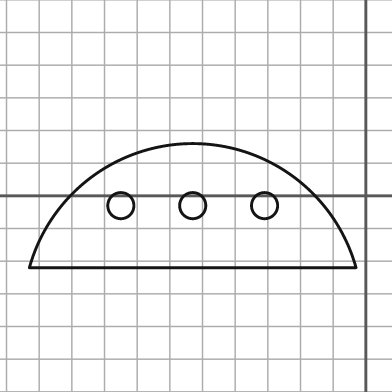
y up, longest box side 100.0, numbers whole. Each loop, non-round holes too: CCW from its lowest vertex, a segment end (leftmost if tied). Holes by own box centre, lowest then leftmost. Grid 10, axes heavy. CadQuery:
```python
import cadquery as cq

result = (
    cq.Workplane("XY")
    .moveTo(-103.0, -22.0)
    .lineTo(-3.0, -22.0)
    .threePointArc((-53.0, 16.0), (-103.0, -22.0))
    .close()
    .moveTo(-75.0, -3.0)
    .circle(4.0)
    .moveTo(-53.0, -3.0)
    .circle(4.0)
    .moveTo(-31.0, -3.0)
    .circle(4.0)
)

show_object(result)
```